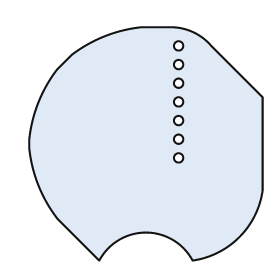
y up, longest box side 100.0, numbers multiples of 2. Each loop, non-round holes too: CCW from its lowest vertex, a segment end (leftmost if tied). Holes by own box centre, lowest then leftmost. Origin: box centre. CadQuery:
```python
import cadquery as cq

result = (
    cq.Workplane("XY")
    .moveTo(-20.0, -50.0)
    .threePointArc((0.0, -38.0), (20.0, -50.0))
    .threePointArc((40.0, -40.0), (50.0, -20.0))
    .lineTo(50.0, 20.0)
    .lineTo(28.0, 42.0)
    .threePointArc((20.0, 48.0), (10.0, 50.0))
    .lineTo(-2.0, 50.0)
    .threePointArc((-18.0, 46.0), (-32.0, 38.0))
    .lineTo(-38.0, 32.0)
    .threePointArc((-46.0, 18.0), (-50.0, 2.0))
    .lineTo(-50.0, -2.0)
    .threePointArc((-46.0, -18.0), (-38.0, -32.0))
    .close()
    .moveTo(14.0, -6.0)
    .circle(2.0)
    .moveTo(14.0, 2.0)
    .circle(2.0)
    .moveTo(14.0, 10.0)
    .circle(2.0)
    .moveTo(14.0, 18.0)
    .circle(2.0)
    .moveTo(14.0, 26.0)
    .circle(2.0)
    .moveTo(14.0, 34.0)
    .circle(2.0)
    .moveTo(14.0, 42.0)
    .circle(2.0)
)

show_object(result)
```